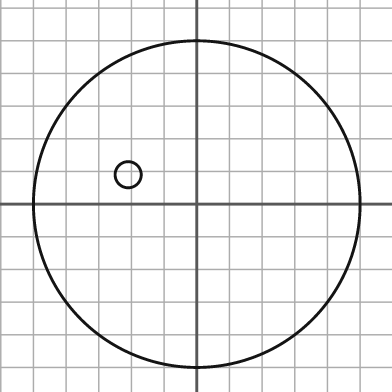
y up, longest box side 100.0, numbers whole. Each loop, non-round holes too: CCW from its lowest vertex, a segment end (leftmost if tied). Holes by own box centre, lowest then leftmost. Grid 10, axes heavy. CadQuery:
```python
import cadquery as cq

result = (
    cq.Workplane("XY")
    .moveTo(0.0, 0.0)
    .circle(50.0)
    .moveTo(-21.0, 9.0)
    .circle(4.0)
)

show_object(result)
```